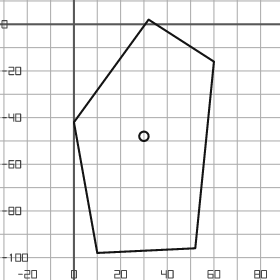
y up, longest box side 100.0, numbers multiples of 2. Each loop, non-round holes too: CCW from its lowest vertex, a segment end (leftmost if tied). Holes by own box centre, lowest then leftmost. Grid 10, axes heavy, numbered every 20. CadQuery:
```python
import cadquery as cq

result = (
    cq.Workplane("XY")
    .moveTo(10.0, -98.0)
    .lineTo(52.0, -96.0)
    .lineTo(60.0, -16.0)
    .lineTo(32.0, 2.0)
    .lineTo(0.0, -42.0)
    .close()
    .moveTo(30.0, -48.0)
    .circle(2.0)
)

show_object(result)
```